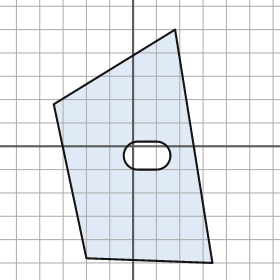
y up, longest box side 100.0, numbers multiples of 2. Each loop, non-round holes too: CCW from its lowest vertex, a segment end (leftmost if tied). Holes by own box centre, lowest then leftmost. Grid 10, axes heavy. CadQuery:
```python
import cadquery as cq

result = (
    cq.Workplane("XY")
    .moveTo(34.0, -50.0)
    .lineTo(18.0, 50.0)
    .lineTo(-34.0, 18.0)
    .lineTo(-20.0, -48.0)
    .close()
    .moveTo(2.0, -10.0)
    .lineTo(10.0, -10.0)
    .threePointArc((16.0, -4.0), (10.0, 2.0))
    .lineTo(2.0, 2.0)
    .threePointArc((-4.0, -4.0), (2.0, -10.0))
    .close()
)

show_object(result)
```